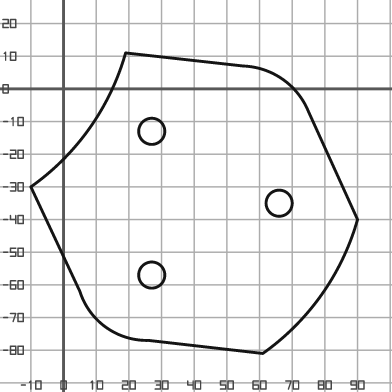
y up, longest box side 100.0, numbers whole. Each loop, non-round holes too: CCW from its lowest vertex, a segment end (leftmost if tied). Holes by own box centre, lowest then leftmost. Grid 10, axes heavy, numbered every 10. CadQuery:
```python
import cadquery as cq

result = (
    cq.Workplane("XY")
    .moveTo(61.0, -81.0)
    .threePointArc((79.0, -63.0), (90.0, -40.0))
    .lineTo(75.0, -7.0)
    .threePointArc((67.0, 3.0), (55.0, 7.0))
    .lineTo(19.0, 11.0)
    .threePointArc((8.0, -12.0), (-10.0, -30.0))
    .lineTo(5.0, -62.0)
    .threePointArc((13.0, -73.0), (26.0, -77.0))
    .close()
    .moveTo(27.0, -57.0)
    .circle(4.0)
    .moveTo(66.0, -35.0)
    .circle(4.0)
    .moveTo(27.0, -13.0)
    .circle(4.0)
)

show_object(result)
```